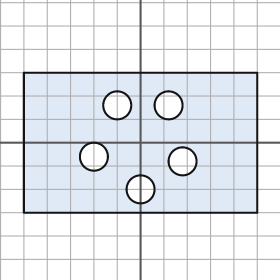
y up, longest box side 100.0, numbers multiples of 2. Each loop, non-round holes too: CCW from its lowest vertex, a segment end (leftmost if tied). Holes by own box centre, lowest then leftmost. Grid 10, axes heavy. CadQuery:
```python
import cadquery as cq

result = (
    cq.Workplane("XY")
    .moveTo(-50.0, -30.0)
    .lineTo(50.0, -30.0)
    .lineTo(50.0, 30.0)
    .lineTo(-50.0, 30.0)
    .close()
    .moveTo(0.0, -20.0)
    .circle(6.0)
    .moveTo(18.0, -8.0)
    .circle(6.0)
    .moveTo(-20.0, -6.0)
    .circle(6.0)
    .moveTo(-10.0, 16.0)
    .circle(6.0)
    .moveTo(12.0, 16.0)
    .circle(6.0)
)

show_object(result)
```